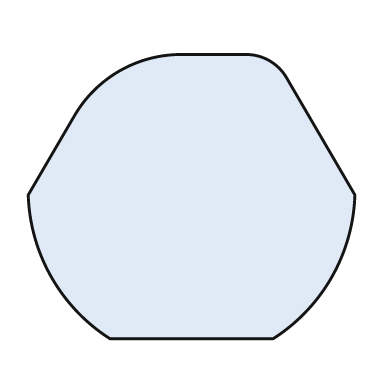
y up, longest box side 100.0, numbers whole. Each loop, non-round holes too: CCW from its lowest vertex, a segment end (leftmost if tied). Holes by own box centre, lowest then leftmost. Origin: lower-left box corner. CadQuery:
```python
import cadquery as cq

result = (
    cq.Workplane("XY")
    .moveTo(25.0, 0.0)
    .lineTo(75.0, 0.0)
    .threePointArc((93.0, 19.0), (100.0, 44.0))
    .lineTo(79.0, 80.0)
    .threePointArc((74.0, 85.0), (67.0, 87.0))
    .lineTo(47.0, 87.0)
    .threePointArc((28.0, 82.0), (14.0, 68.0))
    .lineTo(0.0, 44.0)
    .threePointArc((7.0, 19.0), (25.0, 0.0))
    .close()
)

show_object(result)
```